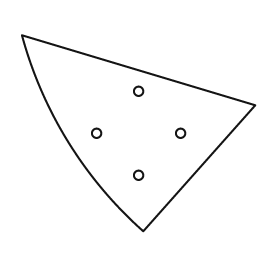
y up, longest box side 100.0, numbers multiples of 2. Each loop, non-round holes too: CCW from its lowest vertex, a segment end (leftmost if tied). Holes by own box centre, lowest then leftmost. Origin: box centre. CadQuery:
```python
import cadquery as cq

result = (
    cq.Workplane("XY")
    .moveTo(2.0, -42.0)
    .lineTo(50.0, 12.0)
    .lineTo(-50.0, 42.0)
    .threePointArc((-30.0, -4.0), (2.0, -42.0))
    .close()
    .moveTo(0.0, -18.0)
    .circle(2.0)
    .moveTo(-18.0, 0.0)
    .circle(2.0)
    .moveTo(18.0, 0.0)
    .circle(2.0)
    .moveTo(0.0, 18.0)
    .circle(2.0)
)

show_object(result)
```